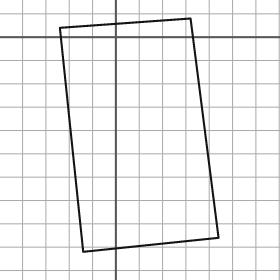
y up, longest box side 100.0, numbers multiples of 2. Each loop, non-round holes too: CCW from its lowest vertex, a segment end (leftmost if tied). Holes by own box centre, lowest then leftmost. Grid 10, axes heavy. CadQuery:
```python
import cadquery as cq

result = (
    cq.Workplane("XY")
    .moveTo(-14.0, -92.0)
    .lineTo(44.0, -86.0)
    .lineTo(32.0, 8.0)
    .lineTo(-24.0, 4.0)
    .close()
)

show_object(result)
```